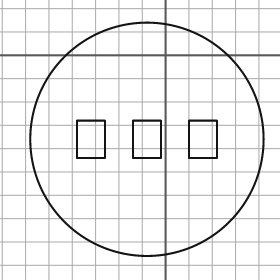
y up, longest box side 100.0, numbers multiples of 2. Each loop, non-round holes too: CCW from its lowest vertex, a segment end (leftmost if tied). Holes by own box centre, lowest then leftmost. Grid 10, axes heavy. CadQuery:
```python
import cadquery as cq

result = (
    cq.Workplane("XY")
    .moveTo(-8.0, -36.0)
    .circle(50.0)
    .moveTo(-38.0, -44.0)
    .lineTo(-26.0, -44.0)
    .lineTo(-26.0, -28.0)
    .lineTo(-38.0, -28.0)
    .close()
    .moveTo(-14.0, -44.0)
    .lineTo(-2.0, -44.0)
    .lineTo(-2.0, -28.0)
    .lineTo(-14.0, -28.0)
    .close()
    .moveTo(10.0, -44.0)
    .lineTo(22.0, -44.0)
    .lineTo(22.0, -28.0)
    .lineTo(10.0, -28.0)
    .close()
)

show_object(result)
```